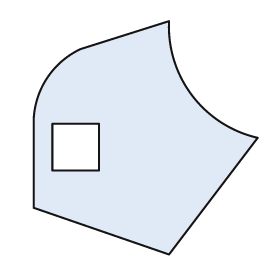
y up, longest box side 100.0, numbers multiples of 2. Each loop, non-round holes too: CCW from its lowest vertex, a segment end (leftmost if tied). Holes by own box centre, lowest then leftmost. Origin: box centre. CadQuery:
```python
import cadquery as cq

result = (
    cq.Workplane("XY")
    .moveTo(10.0, -50.0)
    .lineTo(48.0, 0.0)
    .threePointArc((20.0, 18.0), (10.0, 50.0))
    .lineTo(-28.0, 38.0)
    .threePointArc((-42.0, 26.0), (-48.0, 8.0))
    .lineTo(-48.0, -30.0)
    .close()
    .moveTo(-40.0, -14.0)
    .lineTo(-20.0, -14.0)
    .lineTo(-20.0, 6.0)
    .lineTo(-40.0, 6.0)
    .close()
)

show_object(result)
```